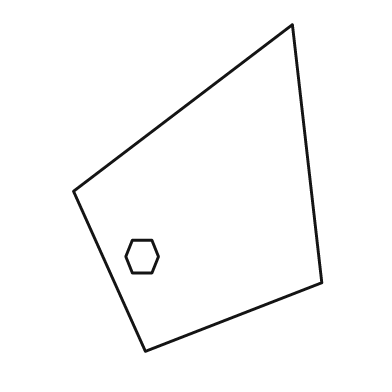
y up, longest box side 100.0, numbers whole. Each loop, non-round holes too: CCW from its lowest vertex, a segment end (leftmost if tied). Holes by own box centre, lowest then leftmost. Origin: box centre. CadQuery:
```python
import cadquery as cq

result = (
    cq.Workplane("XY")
    .moveTo(-16.0, -50.0)
    .lineTo(38.0, -29.0)
    .lineTo(29.0, 50.0)
    .lineTo(-38.0, -1.0)
    .close()
    .moveTo(-20.0, -26.0)
    .lineTo(-14.0, -26.0)
    .lineTo(-12.0, -21.0)
    .lineTo(-14.0, -16.0)
    .lineTo(-20.0, -16.0)
    .lineTo(-22.0, -21.0)
    .close()
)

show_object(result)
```